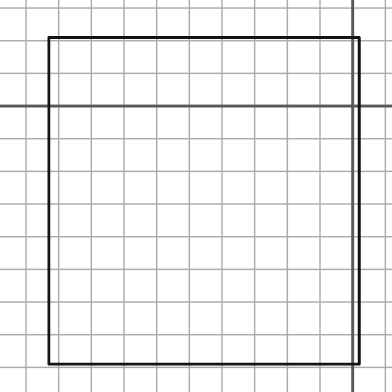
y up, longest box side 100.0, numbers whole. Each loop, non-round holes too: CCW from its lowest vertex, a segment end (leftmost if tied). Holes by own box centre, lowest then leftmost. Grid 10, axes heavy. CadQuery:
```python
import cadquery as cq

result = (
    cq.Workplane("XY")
    .moveTo(-93.0, -79.0)
    .lineTo(2.0, -79.0)
    .lineTo(2.0, 21.0)
    .lineTo(-93.0, 21.0)
    .close()
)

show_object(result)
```